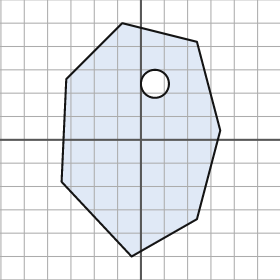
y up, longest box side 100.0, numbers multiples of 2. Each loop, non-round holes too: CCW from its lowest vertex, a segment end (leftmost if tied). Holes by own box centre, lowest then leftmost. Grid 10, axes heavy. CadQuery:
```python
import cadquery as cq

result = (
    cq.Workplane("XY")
    .moveTo(-4.0, -50.0)
    .lineTo(24.0, -34.0)
    .lineTo(34.0, 4.0)
    .lineTo(24.0, 42.0)
    .lineTo(-8.0, 50.0)
    .lineTo(-32.0, 26.0)
    .lineTo(-34.0, -18.0)
    .close()
    .moveTo(6.0, 24.0)
    .circle(6.0)
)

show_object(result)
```